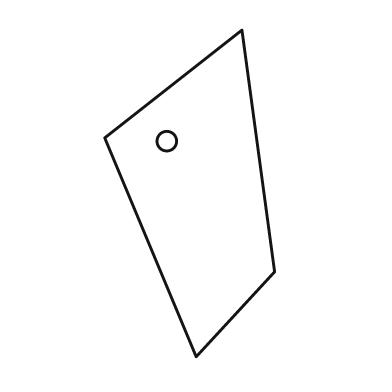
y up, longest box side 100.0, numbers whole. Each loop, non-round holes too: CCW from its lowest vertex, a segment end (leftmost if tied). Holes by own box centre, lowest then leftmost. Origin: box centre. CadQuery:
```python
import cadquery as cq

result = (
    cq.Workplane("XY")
    .moveTo(2.0, -50.0)
    .lineTo(26.0, -24.0)
    .lineTo(16.0, 50.0)
    .lineTo(-26.0, 17.0)
    .close()
    .moveTo(-7.0, 16.0)
    .circle(3.0)
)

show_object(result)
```